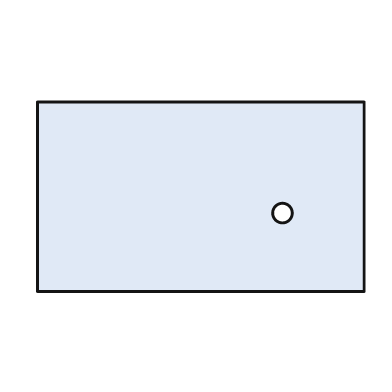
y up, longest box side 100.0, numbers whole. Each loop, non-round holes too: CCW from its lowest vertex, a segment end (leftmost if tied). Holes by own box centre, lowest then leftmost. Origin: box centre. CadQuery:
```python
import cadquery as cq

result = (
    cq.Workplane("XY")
    .moveTo(-50.0, -29.0)
    .lineTo(50.0, -29.0)
    .lineTo(50.0, 29.0)
    .lineTo(-50.0, 29.0)
    .close()
    .moveTo(25.0, -5.0)
    .circle(3.0)
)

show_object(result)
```